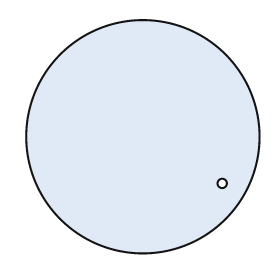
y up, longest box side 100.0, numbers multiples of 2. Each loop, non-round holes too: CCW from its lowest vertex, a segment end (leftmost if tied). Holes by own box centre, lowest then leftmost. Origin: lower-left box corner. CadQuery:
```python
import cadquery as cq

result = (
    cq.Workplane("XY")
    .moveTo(50.0, 50.0)
    .circle(50.0)
    .moveTo(84.0, 30.0)
    .circle(2.0)
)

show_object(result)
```